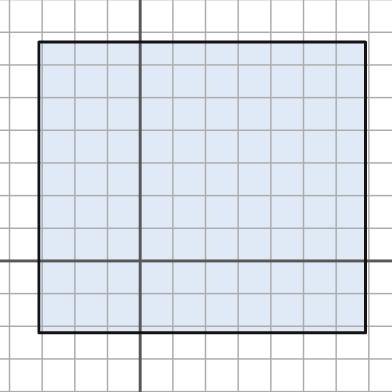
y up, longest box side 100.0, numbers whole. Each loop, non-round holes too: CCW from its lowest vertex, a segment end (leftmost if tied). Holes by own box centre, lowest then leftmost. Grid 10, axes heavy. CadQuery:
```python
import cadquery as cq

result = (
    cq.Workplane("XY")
    .moveTo(-31.0, -22.0)
    .lineTo(69.0, -22.0)
    .lineTo(69.0, 67.0)
    .lineTo(-31.0, 67.0)
    .close()
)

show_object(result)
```